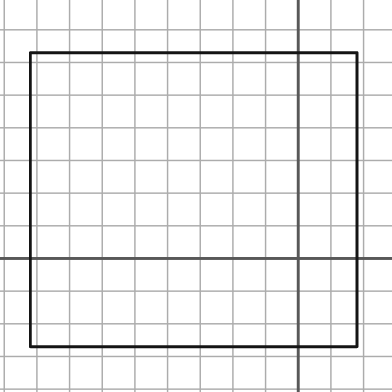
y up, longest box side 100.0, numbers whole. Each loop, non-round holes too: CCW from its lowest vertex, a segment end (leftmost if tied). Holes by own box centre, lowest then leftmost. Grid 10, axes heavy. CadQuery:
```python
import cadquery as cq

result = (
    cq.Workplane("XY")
    .moveTo(-82.0, -27.0)
    .lineTo(18.0, -27.0)
    .lineTo(18.0, 63.0)
    .lineTo(-82.0, 63.0)
    .close()
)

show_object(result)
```